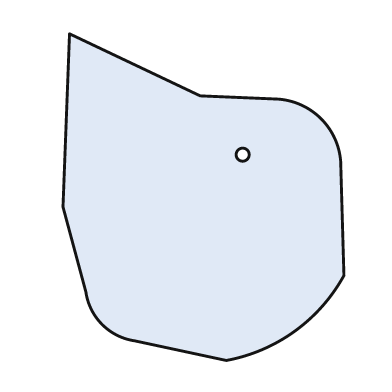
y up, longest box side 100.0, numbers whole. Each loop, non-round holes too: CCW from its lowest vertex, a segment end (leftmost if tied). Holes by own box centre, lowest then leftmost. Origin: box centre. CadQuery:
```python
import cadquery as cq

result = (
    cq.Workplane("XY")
    .moveTo(7.0, -50.0)
    .threePointArc((28.0, -41.0), (43.0, -24.0))
    .lineTo(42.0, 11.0)
    .threePointArc((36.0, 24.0), (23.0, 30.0))
    .lineTo(-1.0, 31.0)
    .lineTo(-41.0, 50.0)
    .lineTo(-43.0, -3.0)
    .lineTo(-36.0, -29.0)
    .threePointArc((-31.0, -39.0), (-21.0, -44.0))
    .close()
    .moveTo(12.0, 13.0)
    .circle(2.0)
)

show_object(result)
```